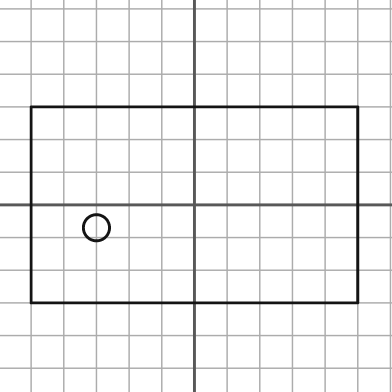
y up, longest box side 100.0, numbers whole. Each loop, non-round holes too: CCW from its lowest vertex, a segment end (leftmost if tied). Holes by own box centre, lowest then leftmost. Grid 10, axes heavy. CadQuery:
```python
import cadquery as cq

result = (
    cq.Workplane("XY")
    .moveTo(-50.0, -30.0)
    .lineTo(50.0, -30.0)
    .lineTo(50.0, 30.0)
    .lineTo(-50.0, 30.0)
    .close()
    .moveTo(-30.0, -7.0)
    .circle(4.0)
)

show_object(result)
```